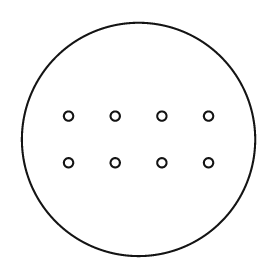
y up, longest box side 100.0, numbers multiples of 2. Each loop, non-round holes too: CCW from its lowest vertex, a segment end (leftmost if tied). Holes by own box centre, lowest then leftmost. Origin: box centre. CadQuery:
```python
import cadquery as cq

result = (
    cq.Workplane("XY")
    .moveTo(0.0, 0.0)
    .circle(50.0)
    .moveTo(-30.0, -10.0)
    .circle(2.0)
    .moveTo(-10.0, -10.0)
    .circle(2.0)
    .moveTo(10.0, -10.0)
    .circle(2.0)
    .moveTo(30.0, -10.0)
    .circle(2.0)
    .moveTo(-30.0, 10.0)
    .circle(2.0)
    .moveTo(-10.0, 10.0)
    .circle(2.0)
    .moveTo(10.0, 10.0)
    .circle(2.0)
    .moveTo(30.0, 10.0)
    .circle(2.0)
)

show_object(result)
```